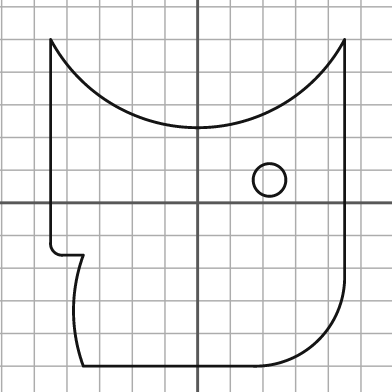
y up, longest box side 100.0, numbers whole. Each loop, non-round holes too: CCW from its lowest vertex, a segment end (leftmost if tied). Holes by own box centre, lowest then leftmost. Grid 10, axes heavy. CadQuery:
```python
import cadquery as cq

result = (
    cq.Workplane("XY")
    .moveTo(-35.0, -50.0)
    .lineTo(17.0, -50.0)
    .threePointArc((37.0, -42.0), (45.0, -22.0))
    .lineTo(45.0, 50.0)
    .threePointArc((0.0, 23.0), (-45.0, 50.0))
    .lineTo(-45.0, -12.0)
    .threePointArc((-44.0, -15.0), (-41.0, -16.0))
    .lineTo(-35.0, -16.0)
    .threePointArc((-38.0, -33.0), (-35.0, -50.0))
    .close()
    .moveTo(22.0, 7.0)
    .circle(5.0)
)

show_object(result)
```